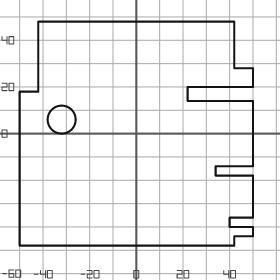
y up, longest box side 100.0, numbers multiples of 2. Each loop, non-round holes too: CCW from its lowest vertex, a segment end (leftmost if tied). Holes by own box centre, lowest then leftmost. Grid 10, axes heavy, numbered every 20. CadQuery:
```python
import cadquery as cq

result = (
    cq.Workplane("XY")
    .moveTo(-50.0, -48.0)
    .lineTo(42.0, -48.0)
    .lineTo(42.0, -44.0)
    .lineTo(50.0, -44.0)
    .lineTo(50.0, -40.0)
    .lineTo(40.0, -40.0)
    .lineTo(40.0, -36.0)
    .lineTo(50.0, -36.0)
    .lineTo(50.0, -18.0)
    .lineTo(34.0, -18.0)
    .lineTo(34.0, -14.0)
    .lineTo(50.0, -14.0)
    .lineTo(50.0, 14.0)
    .lineTo(22.0, 14.0)
    .lineTo(22.0, 20.0)
    .lineTo(50.0, 20.0)
    .lineTo(50.0, 28.0)
    .lineTo(42.0, 28.0)
    .lineTo(42.0, 48.0)
    .lineTo(-42.0, 48.0)
    .lineTo(-42.0, 18.0)
    .lineTo(-50.0, 18.0)
    .close()
    .moveTo(-32.0, 6.0)
    .circle(6.0)
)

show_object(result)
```